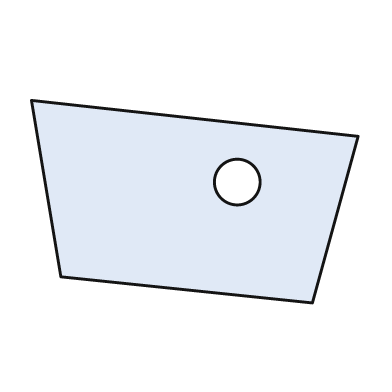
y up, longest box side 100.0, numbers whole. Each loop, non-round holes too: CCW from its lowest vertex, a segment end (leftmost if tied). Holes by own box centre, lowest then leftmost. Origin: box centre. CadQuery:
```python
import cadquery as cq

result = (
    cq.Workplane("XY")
    .moveTo(36.0, -31.0)
    .lineTo(50.0, 20.0)
    .lineTo(-50.0, 31.0)
    .lineTo(-41.0, -23.0)
    .close()
    .moveTo(13.0, 6.0)
    .circle(7.0)
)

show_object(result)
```